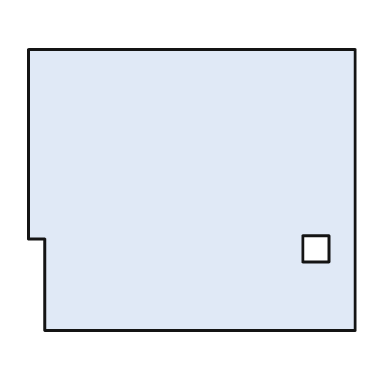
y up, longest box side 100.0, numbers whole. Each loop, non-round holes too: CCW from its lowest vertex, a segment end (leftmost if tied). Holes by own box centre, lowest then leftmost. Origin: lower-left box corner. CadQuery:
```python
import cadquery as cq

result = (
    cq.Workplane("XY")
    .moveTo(5.0, 0.0)
    .lineTo(100.0, 0.0)
    .lineTo(100.0, 86.0)
    .lineTo(0.0, 86.0)
    .lineTo(0.0, 28.0)
    .lineTo(5.0, 28.0)
    .close()
    .moveTo(84.0, 21.0)
    .lineTo(92.0, 21.0)
    .lineTo(92.0, 29.0)
    .lineTo(84.0, 29.0)
    .close()
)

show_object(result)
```